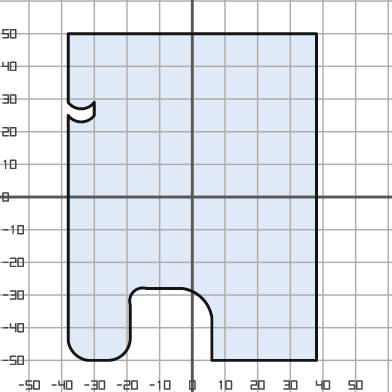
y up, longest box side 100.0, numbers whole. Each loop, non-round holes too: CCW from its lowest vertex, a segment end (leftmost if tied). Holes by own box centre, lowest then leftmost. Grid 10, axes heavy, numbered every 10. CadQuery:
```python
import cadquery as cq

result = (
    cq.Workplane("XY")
    .moveTo(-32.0, -50.0)
    .lineTo(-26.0, -50.0)
    .threePointArc((-21.0, -48.0), (-19.0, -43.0))
    .lineTo(-19.0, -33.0)
    .threePointArc((-18.0, -29.0), (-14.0, -28.0))
    .lineTo(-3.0, -28.0)
    .threePointArc((3.0, -31.0), (6.0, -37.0))
    .lineTo(6.0, -50.0)
    .lineTo(38.0, -50.0)
    .lineTo(38.0, 50.0)
    .lineTo(-38.0, 50.0)
    .lineTo(-38.0, 29.0)
    .threePointArc((-34.0, 27.0), (-30.0, 29.0))
    .lineTo(-30.0, 25.0)
    .threePointArc((-34.0, 23.0), (-38.0, 25.0))
    .lineTo(-38.0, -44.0)
    .threePointArc((-36.0, -48.0), (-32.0, -50.0))
    .close()
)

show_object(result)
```